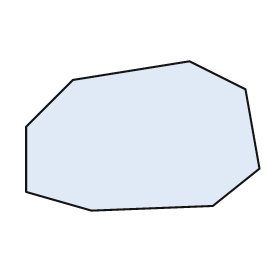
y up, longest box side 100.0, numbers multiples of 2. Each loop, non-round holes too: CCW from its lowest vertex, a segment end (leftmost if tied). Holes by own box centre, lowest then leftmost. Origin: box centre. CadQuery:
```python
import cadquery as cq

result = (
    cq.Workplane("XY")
    .moveTo(-22.0, -32.0)
    .lineTo(30.0, -30.0)
    .lineTo(50.0, -14.0)
    .lineTo(44.0, 20.0)
    .lineTo(20.0, 32.0)
    .lineTo(-30.0, 24.0)
    .lineTo(-50.0, 4.0)
    .lineTo(-50.0, -24.0)
    .close()
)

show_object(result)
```